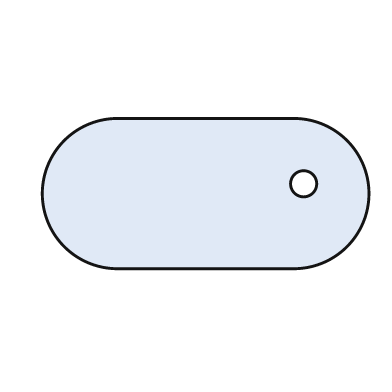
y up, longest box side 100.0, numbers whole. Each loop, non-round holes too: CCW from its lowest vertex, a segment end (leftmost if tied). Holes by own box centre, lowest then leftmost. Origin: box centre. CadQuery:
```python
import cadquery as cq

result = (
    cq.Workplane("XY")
    .moveTo(-27.0, -23.0)
    .lineTo(27.0, -23.0)
    .threePointArc((50.0, 0.0), (27.0, 23.0))
    .lineTo(-27.0, 23.0)
    .threePointArc((-50.0, 0.0), (-27.0, -23.0))
    .close()
    .moveTo(30.0, 3.0)
    .circle(4.0)
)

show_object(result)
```